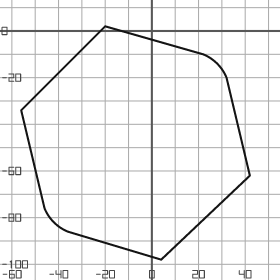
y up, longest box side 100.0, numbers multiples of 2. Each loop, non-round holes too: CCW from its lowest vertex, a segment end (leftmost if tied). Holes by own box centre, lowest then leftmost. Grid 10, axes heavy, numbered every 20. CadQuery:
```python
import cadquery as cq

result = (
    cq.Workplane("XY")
    .moveTo(4.0, -98.0)
    .lineTo(42.0, -62.0)
    .lineTo(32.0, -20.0)
    .threePointArc((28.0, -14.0), (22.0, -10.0))
    .lineTo(-20.0, 2.0)
    .lineTo(-56.0, -34.0)
    .lineTo(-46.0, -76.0)
    .threePointArc((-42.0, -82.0), (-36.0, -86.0))
    .close()
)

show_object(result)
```